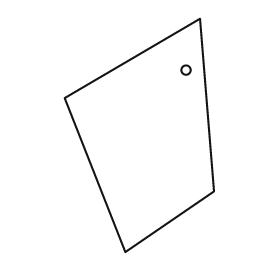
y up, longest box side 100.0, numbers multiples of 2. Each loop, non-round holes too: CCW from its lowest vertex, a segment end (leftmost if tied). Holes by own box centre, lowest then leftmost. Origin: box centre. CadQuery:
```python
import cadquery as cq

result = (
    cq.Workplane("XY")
    .moveTo(-6.0, -50.0)
    .lineTo(32.0, -24.0)
    .lineTo(26.0, 50.0)
    .lineTo(-32.0, 16.0)
    .close()
    .moveTo(20.0, 28.0)
    .circle(2.0)
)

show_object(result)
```